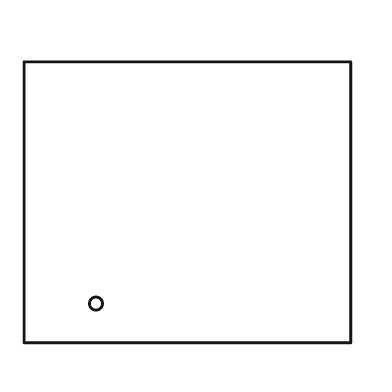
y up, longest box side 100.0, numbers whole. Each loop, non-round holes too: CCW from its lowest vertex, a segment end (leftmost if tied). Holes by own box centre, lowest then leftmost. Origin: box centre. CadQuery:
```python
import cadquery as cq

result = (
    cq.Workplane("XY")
    .moveTo(-50.0, -43.0)
    .lineTo(50.0, -43.0)
    .lineTo(50.0, 43.0)
    .lineTo(-50.0, 43.0)
    .close()
    .moveTo(-28.0, -31.0)
    .circle(2.0)
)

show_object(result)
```